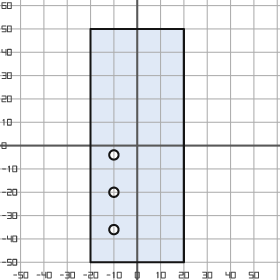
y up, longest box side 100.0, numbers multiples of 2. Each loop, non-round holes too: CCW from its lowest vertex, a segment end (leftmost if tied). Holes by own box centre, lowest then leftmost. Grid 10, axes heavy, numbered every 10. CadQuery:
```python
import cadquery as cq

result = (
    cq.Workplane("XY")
    .moveTo(-20.0, -50.0)
    .lineTo(20.0, -50.0)
    .lineTo(20.0, 50.0)
    .lineTo(-20.0, 50.0)
    .close()
    .moveTo(-10.0, -36.0)
    .circle(2.0)
    .moveTo(-10.0, -20.0)
    .circle(2.0)
    .moveTo(-10.0, -4.0)
    .circle(2.0)
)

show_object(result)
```